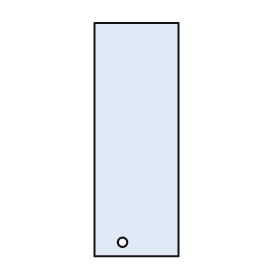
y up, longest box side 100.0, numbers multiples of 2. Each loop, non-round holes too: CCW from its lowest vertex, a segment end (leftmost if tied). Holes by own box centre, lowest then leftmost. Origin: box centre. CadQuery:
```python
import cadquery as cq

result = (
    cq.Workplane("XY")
    .moveTo(-18.0, -50.0)
    .lineTo(18.0, -50.0)
    .lineTo(18.0, 50.0)
    .lineTo(-18.0, 50.0)
    .close()
    .moveTo(-6.0, -44.0)
    .circle(2.0)
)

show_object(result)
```